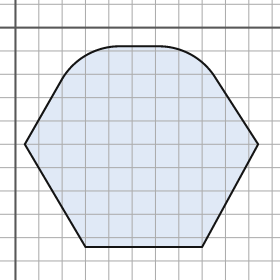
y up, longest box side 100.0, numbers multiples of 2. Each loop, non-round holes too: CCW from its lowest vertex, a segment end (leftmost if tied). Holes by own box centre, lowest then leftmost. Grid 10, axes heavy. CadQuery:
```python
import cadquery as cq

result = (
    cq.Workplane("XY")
    .moveTo(30.0, -94.0)
    .lineTo(80.0, -94.0)
    .lineTo(104.0, -50.0)
    .lineTo(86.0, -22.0)
    .threePointArc((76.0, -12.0), (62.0, -8.0))
    .lineTo(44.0, -8.0)
    .threePointArc((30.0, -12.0), (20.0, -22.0))
    .lineTo(4.0, -50.0)
    .close()
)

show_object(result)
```